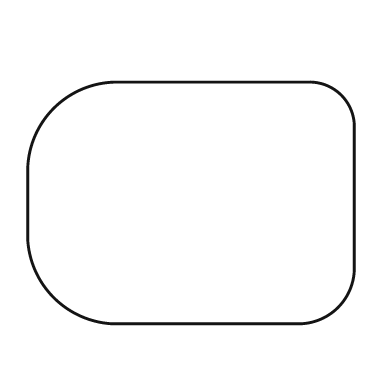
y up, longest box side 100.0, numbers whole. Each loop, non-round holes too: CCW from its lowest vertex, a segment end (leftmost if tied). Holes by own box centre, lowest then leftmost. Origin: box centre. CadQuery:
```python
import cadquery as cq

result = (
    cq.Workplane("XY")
    .moveTo(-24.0, -37.0)
    .lineTo(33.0, -37.0)
    .threePointArc((45.0, -32.0), (50.0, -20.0))
    .lineTo(50.0, 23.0)
    .threePointArc((46.0, 33.0), (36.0, 37.0))
    .lineTo(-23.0, 37.0)
    .threePointArc((-42.0, 29.0), (-50.0, 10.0))
    .lineTo(-50.0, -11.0)
    .threePointArc((-42.0, -29.0), (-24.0, -37.0))
    .close()
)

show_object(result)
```